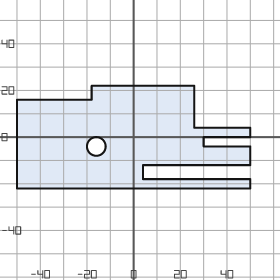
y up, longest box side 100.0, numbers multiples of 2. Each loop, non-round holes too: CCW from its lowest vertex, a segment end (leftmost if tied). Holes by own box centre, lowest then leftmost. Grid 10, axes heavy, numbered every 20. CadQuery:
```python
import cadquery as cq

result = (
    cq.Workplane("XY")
    .moveTo(-50.0, -22.0)
    .lineTo(50.0, -22.0)
    .lineTo(50.0, -18.0)
    .lineTo(4.0, -18.0)
    .lineTo(4.0, -12.0)
    .lineTo(50.0, -12.0)
    .lineTo(50.0, -4.0)
    .lineTo(30.0, -4.0)
    .lineTo(30.0, 0.0)
    .lineTo(50.0, 0.0)
    .lineTo(50.0, 4.0)
    .lineTo(26.0, 4.0)
    .lineTo(26.0, 22.0)
    .lineTo(-18.0, 22.0)
    .lineTo(-18.0, 16.0)
    .lineTo(-50.0, 16.0)
    .close()
    .moveTo(-16.0, -4.0)
    .circle(4.0)
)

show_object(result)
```